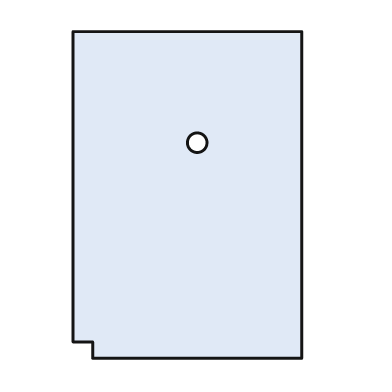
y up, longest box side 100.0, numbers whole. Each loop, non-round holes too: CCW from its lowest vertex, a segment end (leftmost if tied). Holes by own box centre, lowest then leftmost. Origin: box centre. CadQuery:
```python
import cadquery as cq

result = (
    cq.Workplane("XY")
    .moveTo(-29.0, -50.0)
    .lineTo(35.0, -50.0)
    .lineTo(35.0, 50.0)
    .lineTo(-35.0, 50.0)
    .lineTo(-35.0, -45.0)
    .lineTo(-29.0, -45.0)
    .close()
    .moveTo(3.0, 16.0)
    .circle(3.0)
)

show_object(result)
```